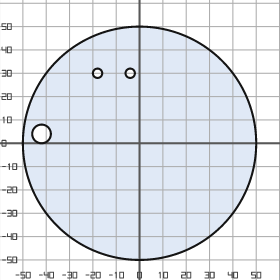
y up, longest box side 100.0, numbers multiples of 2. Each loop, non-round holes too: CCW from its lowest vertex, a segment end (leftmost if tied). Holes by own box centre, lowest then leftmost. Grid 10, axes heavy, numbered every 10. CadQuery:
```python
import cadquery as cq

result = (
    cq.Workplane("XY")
    .moveTo(0.0, 0.0)
    .circle(50.0)
    .moveTo(-42.0, 4.0)
    .circle(4.0)
    .moveTo(-18.0, 30.0)
    .circle(2.0)
    .moveTo(-4.0, 30.0)
    .circle(2.0)
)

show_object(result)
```